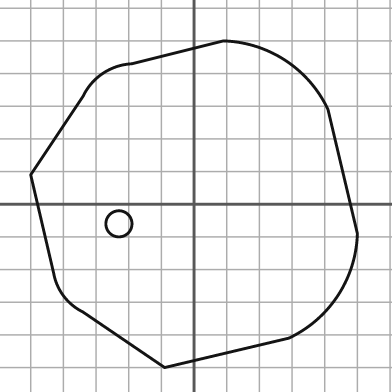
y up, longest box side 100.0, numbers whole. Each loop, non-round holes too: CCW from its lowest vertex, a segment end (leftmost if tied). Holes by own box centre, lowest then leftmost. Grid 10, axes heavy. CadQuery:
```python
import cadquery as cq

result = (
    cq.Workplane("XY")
    .moveTo(-9.0, -50.0)
    .lineTo(29.0, -41.0)
    .threePointArc((44.0, -28.0), (50.0, -9.0))
    .lineTo(41.0, 29.0)
    .threePointArc((28.0, 44.0), (9.0, 50.0))
    .lineTo(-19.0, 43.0)
    .threePointArc((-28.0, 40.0), (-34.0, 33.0))
    .lineTo(-50.0, 9.0)
    .lineTo(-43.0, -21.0)
    .threePointArc((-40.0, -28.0), (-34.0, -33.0))
    .close()
    .moveTo(-23.0, -6.0)
    .circle(4.0)
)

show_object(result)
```